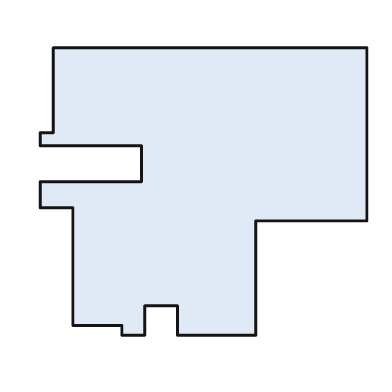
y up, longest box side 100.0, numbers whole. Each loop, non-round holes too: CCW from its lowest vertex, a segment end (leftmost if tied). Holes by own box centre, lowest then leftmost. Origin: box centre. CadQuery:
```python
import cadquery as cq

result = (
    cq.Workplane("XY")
    .moveTo(-25.0, -44.0)
    .lineTo(-18.0, -44.0)
    .lineTo(-18.0, -35.0)
    .lineTo(-8.0, -35.0)
    .lineTo(-8.0, -44.0)
    .lineTo(16.0, -44.0)
    .lineTo(16.0, -9.0)
    .lineTo(50.0, -9.0)
    .lineTo(50.0, 44.0)
    .lineTo(-46.0, 44.0)
    .lineTo(-46.0, 18.0)
    .lineTo(-50.0, 18.0)
    .lineTo(-50.0, 14.0)
    .lineTo(-19.0, 14.0)
    .lineTo(-19.0, 3.0)
    .lineTo(-50.0, 3.0)
    .lineTo(-50.0, -5.0)
    .lineTo(-40.0, -5.0)
    .lineTo(-40.0, -41.0)
    .lineTo(-25.0, -41.0)
    .close()
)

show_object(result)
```